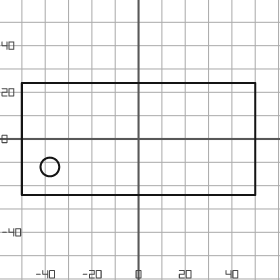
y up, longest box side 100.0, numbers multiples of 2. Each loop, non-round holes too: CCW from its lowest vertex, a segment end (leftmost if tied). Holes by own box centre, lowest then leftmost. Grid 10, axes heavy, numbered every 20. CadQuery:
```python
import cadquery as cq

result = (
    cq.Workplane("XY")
    .moveTo(-50.0, -24.0)
    .lineTo(50.0, -24.0)
    .lineTo(50.0, 24.0)
    .lineTo(-50.0, 24.0)
    .close()
    .moveTo(-38.0, -12.0)
    .circle(4.0)
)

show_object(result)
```